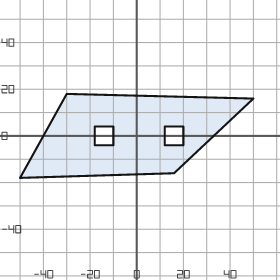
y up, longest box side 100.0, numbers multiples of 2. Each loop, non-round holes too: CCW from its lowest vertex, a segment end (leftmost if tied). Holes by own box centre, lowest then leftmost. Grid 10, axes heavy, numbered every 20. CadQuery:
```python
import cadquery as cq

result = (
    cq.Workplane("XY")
    .moveTo(-50.0, -18.0)
    .lineTo(16.0, -16.0)
    .lineTo(50.0, 16.0)
    .lineTo(-30.0, 18.0)
    .close()
    .moveTo(-18.0, -4.0)
    .lineTo(-10.0, -4.0)
    .lineTo(-10.0, 4.0)
    .lineTo(-18.0, 4.0)
    .close()
    .moveTo(12.0, -4.0)
    .lineTo(20.0, -4.0)
    .lineTo(20.0, 4.0)
    .lineTo(12.0, 4.0)
    .close()
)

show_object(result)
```